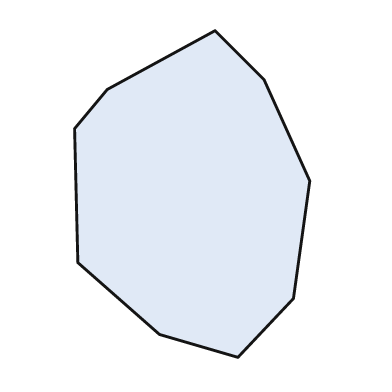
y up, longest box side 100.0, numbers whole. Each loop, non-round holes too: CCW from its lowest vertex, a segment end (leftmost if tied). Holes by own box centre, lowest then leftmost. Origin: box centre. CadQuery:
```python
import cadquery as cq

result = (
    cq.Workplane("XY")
    .moveTo(14.0, -50.0)
    .lineTo(31.0, -32.0)
    .lineTo(36.0, 4.0)
    .lineTo(22.0, 35.0)
    .lineTo(7.0, 50.0)
    .lineTo(-26.0, 32.0)
    .lineTo(-36.0, 20.0)
    .lineTo(-35.0, -21.0)
    .lineTo(-10.0, -43.0)
    .close()
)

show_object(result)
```